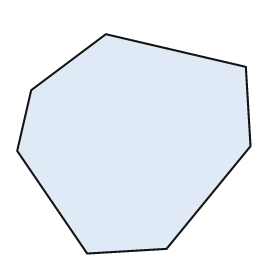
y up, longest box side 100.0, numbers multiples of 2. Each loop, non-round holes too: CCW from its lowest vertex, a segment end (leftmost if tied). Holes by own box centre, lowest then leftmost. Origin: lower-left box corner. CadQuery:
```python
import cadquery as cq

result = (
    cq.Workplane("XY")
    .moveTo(30.0, 0.0)
    .lineTo(64.0, 2.0)
    .lineTo(100.0, 46.0)
    .lineTo(98.0, 80.0)
    .lineTo(38.0, 94.0)
    .lineTo(6.0, 70.0)
    .lineTo(0.0, 44.0)
    .close()
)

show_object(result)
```